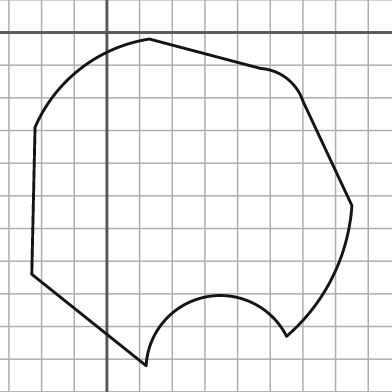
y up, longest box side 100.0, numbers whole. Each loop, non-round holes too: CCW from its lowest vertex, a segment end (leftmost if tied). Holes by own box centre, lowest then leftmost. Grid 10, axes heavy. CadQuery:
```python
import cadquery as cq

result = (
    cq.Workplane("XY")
    .moveTo(12.0, -102.0)
    .threePointArc((30.0, -81.0), (55.0, -93.0))
    .threePointArc((69.0, -75.0), (75.0, -53.0))
    .lineTo(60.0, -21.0)
    .threePointArc((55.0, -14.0), (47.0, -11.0))
    .lineTo(13.0, -2.0)
    .threePointArc((-8.0, -11.0), (-22.0, -29.0))
    .lineTo(-23.0, -74.0)
    .close()
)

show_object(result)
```